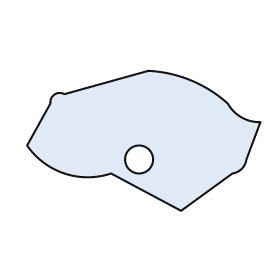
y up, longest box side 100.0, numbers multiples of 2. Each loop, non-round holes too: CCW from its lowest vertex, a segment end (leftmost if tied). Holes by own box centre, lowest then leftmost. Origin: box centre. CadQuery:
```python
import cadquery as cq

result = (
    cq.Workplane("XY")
    .moveTo(16.0, -30.0)
    .lineTo(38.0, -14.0)
    .threePointArc((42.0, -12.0), (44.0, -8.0))
    .lineTo(50.0, 8.0)
    .threePointArc((42.0, 10.0), (36.0, 16.0))
    .threePointArc((20.0, 26.0), (2.0, 30.0))
    .lineTo(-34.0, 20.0)
    .threePointArc((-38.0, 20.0), (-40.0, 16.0))
    .lineTo(-50.0, -2.0)
    .threePointArc((-34.0, -14.0), (-14.0, -14.0))
    .close()
    .moveTo(-2.0, -8.0)
    .circle(6.0)
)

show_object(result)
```